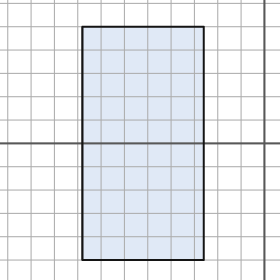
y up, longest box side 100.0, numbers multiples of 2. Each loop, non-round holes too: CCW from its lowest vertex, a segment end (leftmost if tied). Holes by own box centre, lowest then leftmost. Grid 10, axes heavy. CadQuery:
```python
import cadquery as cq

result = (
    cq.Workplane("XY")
    .moveTo(-78.0, -50.0)
    .lineTo(-26.0, -50.0)
    .lineTo(-26.0, 50.0)
    .lineTo(-78.0, 50.0)
    .close()
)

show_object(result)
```